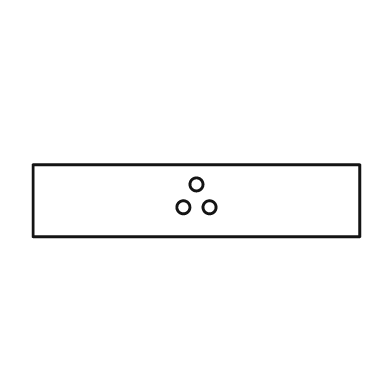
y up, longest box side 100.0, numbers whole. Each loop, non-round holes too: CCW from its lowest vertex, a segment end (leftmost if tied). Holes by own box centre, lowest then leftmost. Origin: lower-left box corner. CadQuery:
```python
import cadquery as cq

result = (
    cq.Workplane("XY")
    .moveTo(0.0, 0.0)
    .lineTo(100.0, 0.0)
    .lineTo(100.0, 22.0)
    .lineTo(0.0, 22.0)
    .close()
    .moveTo(46.0, 9.0)
    .circle(2.0)
    .moveTo(54.0, 9.0)
    .circle(2.0)
    .moveTo(50.0, 16.0)
    .circle(2.0)
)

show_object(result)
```